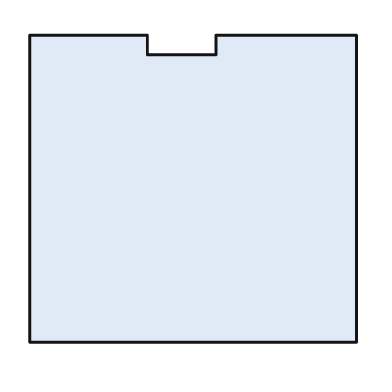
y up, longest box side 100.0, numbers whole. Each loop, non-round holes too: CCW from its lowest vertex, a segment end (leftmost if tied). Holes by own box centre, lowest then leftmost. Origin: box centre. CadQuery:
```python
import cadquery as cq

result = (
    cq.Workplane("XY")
    .moveTo(-50.0, -47.0)
    .lineTo(50.0, -47.0)
    .lineTo(50.0, 47.0)
    .lineTo(7.0, 47.0)
    .lineTo(7.0, 41.0)
    .lineTo(-14.0, 41.0)
    .lineTo(-14.0, 47.0)
    .lineTo(-50.0, 47.0)
    .close()
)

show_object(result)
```